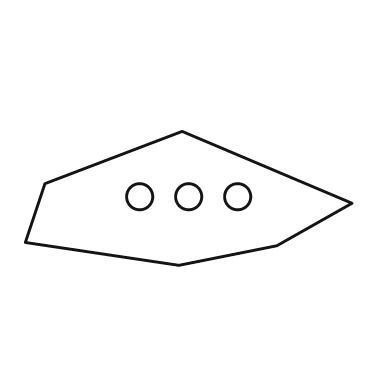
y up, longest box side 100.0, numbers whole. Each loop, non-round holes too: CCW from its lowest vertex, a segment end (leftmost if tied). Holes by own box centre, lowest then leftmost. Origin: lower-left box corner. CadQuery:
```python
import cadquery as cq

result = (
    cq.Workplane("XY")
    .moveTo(47.0, 0.0)
    .lineTo(77.0, 6.0)
    .lineTo(100.0, 19.0)
    .lineTo(48.0, 41.0)
    .lineTo(6.0, 25.0)
    .lineTo(0.0, 7.0)
    .close()
    .moveTo(35.0, 21.0)
    .circle(4.0)
    .moveTo(50.0, 21.0)
    .circle(4.0)
    .moveTo(65.0, 21.0)
    .circle(4.0)
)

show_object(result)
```